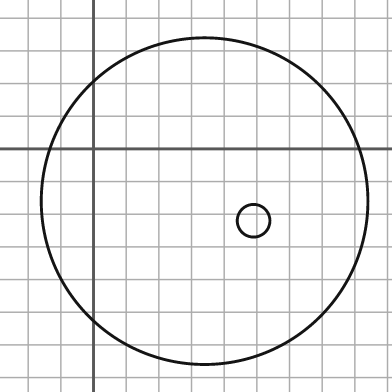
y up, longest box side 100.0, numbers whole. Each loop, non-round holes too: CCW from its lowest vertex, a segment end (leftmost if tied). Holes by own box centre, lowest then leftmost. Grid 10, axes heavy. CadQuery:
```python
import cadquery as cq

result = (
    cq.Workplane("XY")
    .moveTo(34.0, -16.0)
    .circle(50.0)
    .moveTo(49.0, -22.0)
    .circle(5.0)
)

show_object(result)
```